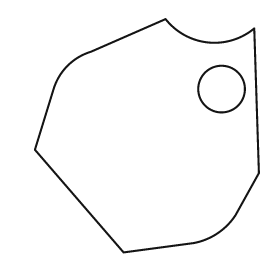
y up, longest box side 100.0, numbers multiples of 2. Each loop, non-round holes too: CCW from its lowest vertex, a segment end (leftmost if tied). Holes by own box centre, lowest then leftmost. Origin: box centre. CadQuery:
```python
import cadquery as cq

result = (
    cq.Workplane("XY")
    .moveTo(-10.0, -50.0)
    .lineTo(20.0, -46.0)
    .threePointArc((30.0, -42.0), (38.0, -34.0))
    .lineTo(48.0, -16.0)
    .lineTo(46.0, 46.0)
    .threePointArc((26.0, 40.0), (8.0, 50.0))
    .lineTo(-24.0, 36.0)
    .threePointArc((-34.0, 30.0), (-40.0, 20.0))
    .lineTo(-48.0, -6.0)
    .close()
    .moveTo(32.0, 20.0)
    .circle(10.0)
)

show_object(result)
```